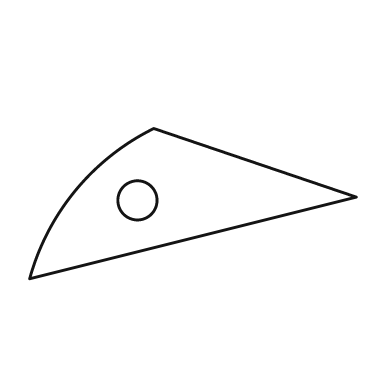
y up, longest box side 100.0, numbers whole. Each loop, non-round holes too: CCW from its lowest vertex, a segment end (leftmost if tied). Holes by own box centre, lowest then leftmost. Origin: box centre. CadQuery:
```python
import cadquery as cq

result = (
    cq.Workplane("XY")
    .moveTo(-50.0, -23.0)
    .lineTo(50.0, 2.0)
    .lineTo(-12.0, 23.0)
    .threePointArc((-36.0, 4.0), (-50.0, -23.0))
    .close()
    .moveTo(-17.0, 1.0)
    .circle(6.0)
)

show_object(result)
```